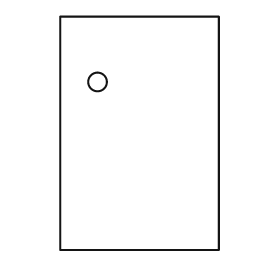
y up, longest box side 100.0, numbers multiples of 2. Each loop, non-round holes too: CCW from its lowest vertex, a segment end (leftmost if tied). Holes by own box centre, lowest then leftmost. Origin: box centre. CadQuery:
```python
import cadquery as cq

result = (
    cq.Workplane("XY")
    .moveTo(-34.0, -50.0)
    .lineTo(34.0, -50.0)
    .lineTo(34.0, 50.0)
    .lineTo(-34.0, 50.0)
    .close()
    .moveTo(-18.0, 22.0)
    .circle(4.0)
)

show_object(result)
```